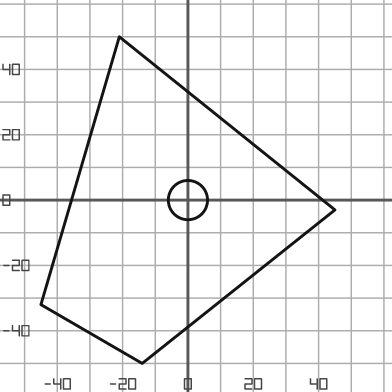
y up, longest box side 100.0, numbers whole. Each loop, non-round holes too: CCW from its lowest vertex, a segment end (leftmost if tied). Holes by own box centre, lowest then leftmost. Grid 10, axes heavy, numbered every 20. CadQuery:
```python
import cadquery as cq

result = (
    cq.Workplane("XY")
    .moveTo(-14.0, -50.0)
    .lineTo(45.0, -3.0)
    .lineTo(-21.0, 50.0)
    .lineTo(-45.0, -32.0)
    .close()
    .moveTo(0.0, 0.0)
    .circle(6.0)
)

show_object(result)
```